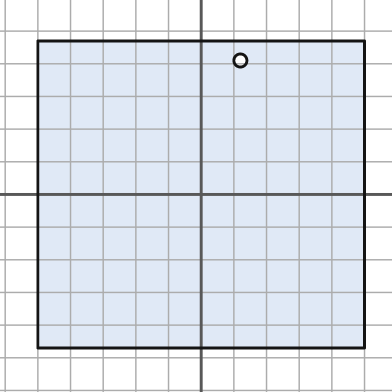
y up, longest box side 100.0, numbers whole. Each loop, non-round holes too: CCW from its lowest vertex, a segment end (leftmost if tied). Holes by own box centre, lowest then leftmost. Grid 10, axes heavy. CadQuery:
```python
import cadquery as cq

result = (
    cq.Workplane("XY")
    .moveTo(-50.0, -47.0)
    .lineTo(50.0, -47.0)
    .lineTo(50.0, 47.0)
    .lineTo(-50.0, 47.0)
    .close()
    .moveTo(12.0, 41.0)
    .circle(2.0)
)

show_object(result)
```